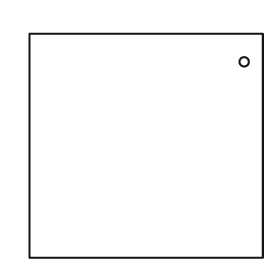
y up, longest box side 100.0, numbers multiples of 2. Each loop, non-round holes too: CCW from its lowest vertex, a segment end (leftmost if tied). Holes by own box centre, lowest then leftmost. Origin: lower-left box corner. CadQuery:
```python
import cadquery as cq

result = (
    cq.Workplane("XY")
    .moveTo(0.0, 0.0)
    .lineTo(100.0, 0.0)
    .lineTo(100.0, 96.0)
    .lineTo(0.0, 96.0)
    .close()
    .moveTo(92.0, 84.0)
    .circle(2.0)
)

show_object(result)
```